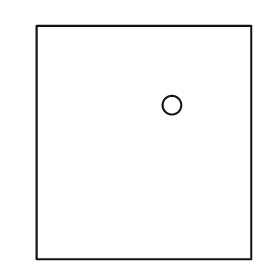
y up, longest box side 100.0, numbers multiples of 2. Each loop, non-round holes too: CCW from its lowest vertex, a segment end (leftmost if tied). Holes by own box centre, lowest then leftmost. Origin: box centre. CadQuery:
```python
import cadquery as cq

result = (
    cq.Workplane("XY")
    .moveTo(-46.0, -50.0)
    .lineTo(46.0, -50.0)
    .lineTo(46.0, 50.0)
    .lineTo(-46.0, 50.0)
    .close()
    .moveTo(12.0, 16.0)
    .circle(4.0)
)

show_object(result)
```